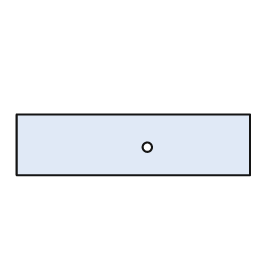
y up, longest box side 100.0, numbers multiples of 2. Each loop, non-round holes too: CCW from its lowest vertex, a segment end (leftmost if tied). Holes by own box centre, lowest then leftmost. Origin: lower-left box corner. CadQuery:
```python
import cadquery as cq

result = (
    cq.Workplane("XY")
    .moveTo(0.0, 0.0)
    .lineTo(100.0, 0.0)
    .lineTo(100.0, 26.0)
    .lineTo(0.0, 26.0)
    .close()
    .moveTo(56.0, 12.0)
    .circle(2.0)
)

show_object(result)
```